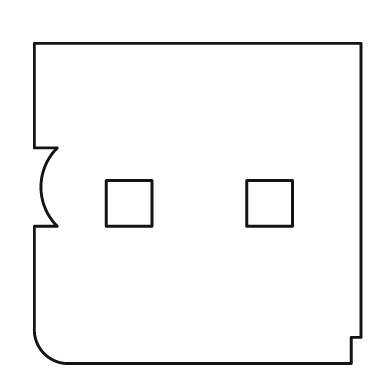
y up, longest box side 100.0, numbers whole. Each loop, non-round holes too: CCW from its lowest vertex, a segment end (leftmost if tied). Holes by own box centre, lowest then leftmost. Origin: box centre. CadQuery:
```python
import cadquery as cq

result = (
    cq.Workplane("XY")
    .moveTo(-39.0, -49.0)
    .lineTo(47.0, -49.0)
    .lineTo(47.0, -41.0)
    .lineTo(50.0, -41.0)
    .lineTo(50.0, 49.0)
    .lineTo(-50.0, 49.0)
    .lineTo(-50.0, 17.0)
    .lineTo(-43.0, 17.0)
    .threePointArc((-48.0, 5.0), (-43.0, -7.0))
    .lineTo(-50.0, -7.0)
    .lineTo(-50.0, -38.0)
    .threePointArc((-47.0, -46.0), (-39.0, -49.0))
    .close()
    .moveTo(-28.0, -7.0)
    .lineTo(-14.0, -7.0)
    .lineTo(-14.0, 7.0)
    .lineTo(-28.0, 7.0)
    .close()
    .moveTo(15.0, -7.0)
    .lineTo(29.0, -7.0)
    .lineTo(29.0, 7.0)
    .lineTo(15.0, 7.0)
    .close()
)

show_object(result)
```